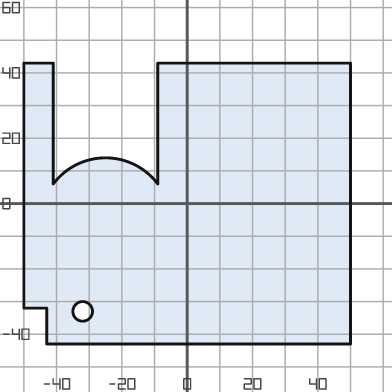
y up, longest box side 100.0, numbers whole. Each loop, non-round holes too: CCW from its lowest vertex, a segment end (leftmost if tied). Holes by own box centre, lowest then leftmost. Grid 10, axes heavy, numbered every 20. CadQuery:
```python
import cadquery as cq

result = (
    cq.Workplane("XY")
    .moveTo(-43.0, -43.0)
    .lineTo(50.0, -43.0)
    .lineTo(50.0, 43.0)
    .lineTo(-9.0, 43.0)
    .lineTo(-9.0, 6.0)
    .threePointArc((-25.0, 14.0), (-41.0, 6.0))
    .lineTo(-41.0, 43.0)
    .lineTo(-50.0, 43.0)
    .lineTo(-50.0, -32.0)
    .lineTo(-43.0, -32.0)
    .close()
    .moveTo(-32.0, -33.0)
    .circle(3.0)
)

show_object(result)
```